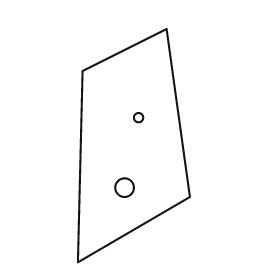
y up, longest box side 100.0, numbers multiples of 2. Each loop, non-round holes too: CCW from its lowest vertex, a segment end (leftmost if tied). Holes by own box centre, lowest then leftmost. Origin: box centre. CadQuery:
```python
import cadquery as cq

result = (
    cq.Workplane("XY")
    .moveTo(-24.0, -50.0)
    .lineTo(24.0, -22.0)
    .lineTo(14.0, 50.0)
    .lineTo(-22.0, 32.0)
    .close()
    .moveTo(-4.0, -18.0)
    .circle(4.0)
    .moveTo(2.0, 12.0)
    .circle(2.0)
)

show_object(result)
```